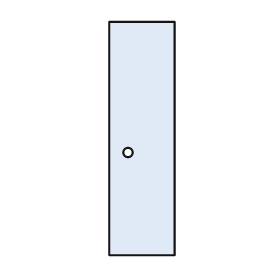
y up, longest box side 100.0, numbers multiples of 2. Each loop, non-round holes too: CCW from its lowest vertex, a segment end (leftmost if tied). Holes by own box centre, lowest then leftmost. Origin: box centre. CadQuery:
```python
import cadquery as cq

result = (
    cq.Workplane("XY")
    .moveTo(-14.0, -50.0)
    .lineTo(14.0, -50.0)
    .lineTo(14.0, 50.0)
    .lineTo(-14.0, 50.0)
    .close()
    .moveTo(-6.0, -6.0)
    .circle(2.0)
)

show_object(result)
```